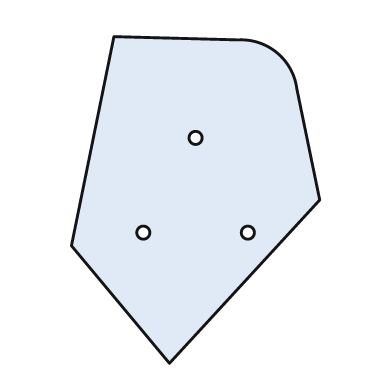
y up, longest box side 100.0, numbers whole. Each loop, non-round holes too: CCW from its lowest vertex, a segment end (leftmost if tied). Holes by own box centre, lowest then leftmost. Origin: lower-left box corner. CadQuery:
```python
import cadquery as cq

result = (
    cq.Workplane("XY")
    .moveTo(30.0, 0.0)
    .lineTo(76.0, 50.0)
    .lineTo(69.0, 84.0)
    .threePointArc((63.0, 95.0), (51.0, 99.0))
    .lineTo(13.0, 100.0)
    .lineTo(0.0, 36.0)
    .close()
    .moveTo(22.0, 40.0)
    .circle(2.0)
    .moveTo(54.0, 40.0)
    .circle(2.0)
    .moveTo(38.0, 69.0)
    .circle(2.0)
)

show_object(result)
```